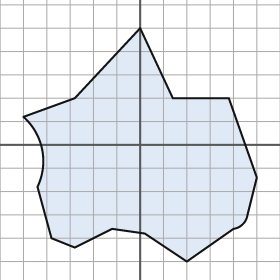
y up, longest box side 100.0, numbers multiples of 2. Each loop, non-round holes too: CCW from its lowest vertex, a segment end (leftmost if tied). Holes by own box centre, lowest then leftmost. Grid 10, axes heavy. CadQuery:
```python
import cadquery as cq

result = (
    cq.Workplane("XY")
    .moveTo(20.0, -50.0)
    .lineTo(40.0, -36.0)
    .threePointArc((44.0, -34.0), (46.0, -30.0))
    .lineTo(50.0, -14.0)
    .lineTo(38.0, 20.0)
    .lineTo(14.0, 20.0)
    .lineTo(0.0, 50.0)
    .lineTo(-28.0, 20.0)
    .lineTo(-50.0, 12.0)
    .threePointArc((-42.0, -2.0), (-44.0, -18.0))
    .lineTo(-38.0, -40.0)
    .lineTo(-28.0, -44.0)
    .lineTo(-12.0, -36.0)
    .lineTo(2.0, -38.0)
    .close()
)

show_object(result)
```